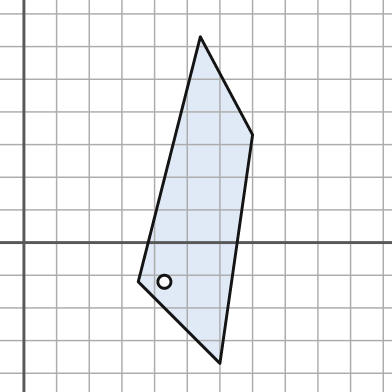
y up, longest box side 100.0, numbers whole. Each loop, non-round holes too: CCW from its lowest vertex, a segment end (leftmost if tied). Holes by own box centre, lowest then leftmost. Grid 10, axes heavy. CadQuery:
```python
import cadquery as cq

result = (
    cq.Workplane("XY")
    .moveTo(60.0, -37.0)
    .lineTo(70.0, 33.0)
    .lineTo(54.0, 63.0)
    .lineTo(35.0, -12.0)
    .close()
    .moveTo(43.0, -12.0)
    .circle(2.0)
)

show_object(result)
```